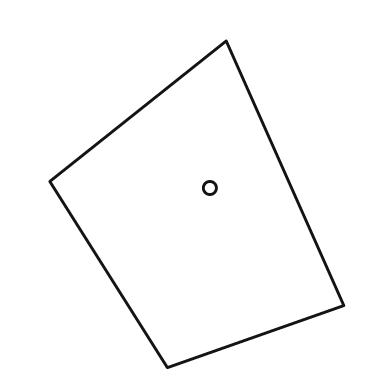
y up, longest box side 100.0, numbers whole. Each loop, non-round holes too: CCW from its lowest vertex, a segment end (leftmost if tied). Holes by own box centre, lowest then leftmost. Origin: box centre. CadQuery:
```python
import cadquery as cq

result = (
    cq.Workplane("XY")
    .moveTo(-9.0, -50.0)
    .lineTo(45.0, -31.0)
    .lineTo(9.0, 50.0)
    .lineTo(-45.0, 7.0)
    .close()
    .moveTo(4.0, 5.0)
    .circle(2.0)
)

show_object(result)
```